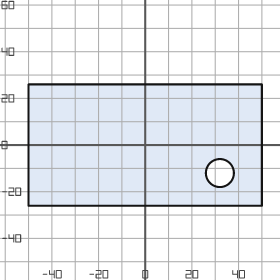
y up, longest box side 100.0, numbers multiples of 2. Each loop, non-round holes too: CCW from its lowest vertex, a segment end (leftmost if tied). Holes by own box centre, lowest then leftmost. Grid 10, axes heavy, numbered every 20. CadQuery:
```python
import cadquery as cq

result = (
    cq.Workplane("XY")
    .moveTo(-50.0, -26.0)
    .lineTo(50.0, -26.0)
    .lineTo(50.0, 26.0)
    .lineTo(-50.0, 26.0)
    .close()
    .moveTo(32.0, -12.0)
    .circle(6.0)
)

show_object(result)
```